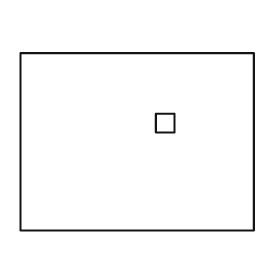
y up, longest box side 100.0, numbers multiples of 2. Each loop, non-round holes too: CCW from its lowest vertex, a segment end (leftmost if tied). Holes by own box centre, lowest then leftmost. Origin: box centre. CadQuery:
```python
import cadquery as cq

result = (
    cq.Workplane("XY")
    .moveTo(-50.0, -38.0)
    .lineTo(50.0, -38.0)
    .lineTo(50.0, 38.0)
    .lineTo(-50.0, 38.0)
    .close()
    .moveTo(8.0, 4.0)
    .lineTo(16.0, 4.0)
    .lineTo(16.0, 12.0)
    .lineTo(8.0, 12.0)
    .close()
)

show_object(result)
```